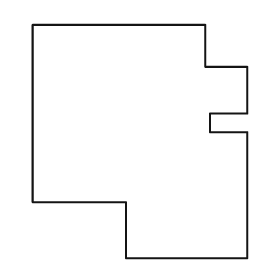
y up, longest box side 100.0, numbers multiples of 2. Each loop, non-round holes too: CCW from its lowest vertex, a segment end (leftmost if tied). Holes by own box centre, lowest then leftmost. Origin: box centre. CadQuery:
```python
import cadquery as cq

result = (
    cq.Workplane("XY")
    .moveTo(-6.0, -50.0)
    .lineTo(46.0, -50.0)
    .lineTo(46.0, 4.0)
    .lineTo(30.0, 4.0)
    .lineTo(30.0, 12.0)
    .lineTo(46.0, 12.0)
    .lineTo(46.0, 32.0)
    .lineTo(28.0, 32.0)
    .lineTo(28.0, 50.0)
    .lineTo(-46.0, 50.0)
    .lineTo(-46.0, -26.0)
    .lineTo(-6.0, -26.0)
    .close()
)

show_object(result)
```